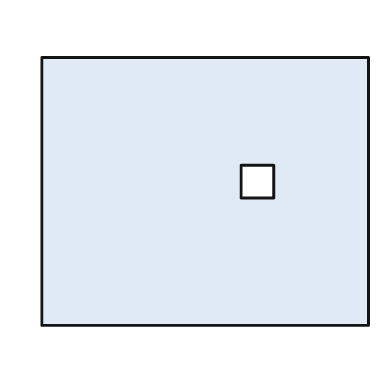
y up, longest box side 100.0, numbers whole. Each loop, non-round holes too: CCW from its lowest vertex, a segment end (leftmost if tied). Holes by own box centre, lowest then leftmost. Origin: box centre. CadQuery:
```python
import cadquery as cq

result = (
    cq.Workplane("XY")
    .moveTo(-50.0, -41.0)
    .lineTo(50.0, -41.0)
    .lineTo(50.0, 41.0)
    .lineTo(-50.0, 41.0)
    .close()
    .moveTo(11.0, -2.0)
    .lineTo(21.0, -2.0)
    .lineTo(21.0, 8.0)
    .lineTo(11.0, 8.0)
    .close()
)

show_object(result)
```